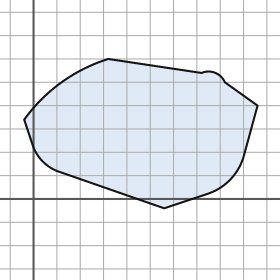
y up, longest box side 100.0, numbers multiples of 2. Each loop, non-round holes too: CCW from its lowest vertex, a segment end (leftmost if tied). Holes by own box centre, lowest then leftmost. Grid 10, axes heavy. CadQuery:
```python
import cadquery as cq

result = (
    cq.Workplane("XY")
    .moveTo(56.0, -4.0)
    .lineTo(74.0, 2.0)
    .threePointArc((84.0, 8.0), (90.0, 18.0))
    .lineTo(96.0, 40.0)
    .lineTo(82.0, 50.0)
    .threePointArc((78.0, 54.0), (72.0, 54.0))
    .lineTo(32.0, 60.0)
    .threePointArc((12.0, 50.0), (-4.0, 34.0))
    .lineTo(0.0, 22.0)
    .threePointArc((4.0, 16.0), (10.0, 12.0))
    .close()
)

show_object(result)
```